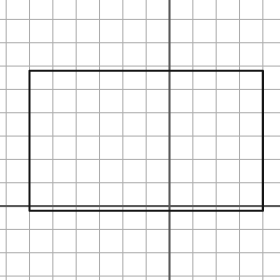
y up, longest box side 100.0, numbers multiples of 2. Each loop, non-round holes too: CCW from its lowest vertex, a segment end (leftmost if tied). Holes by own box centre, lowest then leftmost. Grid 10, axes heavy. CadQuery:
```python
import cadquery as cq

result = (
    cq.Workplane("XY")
    .moveTo(-60.0, -2.0)
    .lineTo(40.0, -2.0)
    .lineTo(40.0, 58.0)
    .lineTo(-60.0, 58.0)
    .close()
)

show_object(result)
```